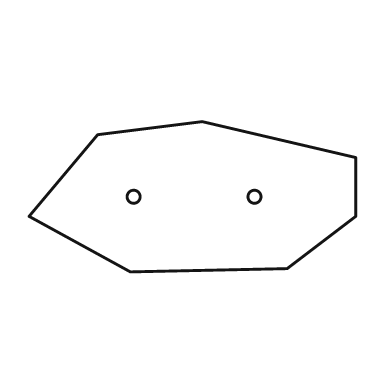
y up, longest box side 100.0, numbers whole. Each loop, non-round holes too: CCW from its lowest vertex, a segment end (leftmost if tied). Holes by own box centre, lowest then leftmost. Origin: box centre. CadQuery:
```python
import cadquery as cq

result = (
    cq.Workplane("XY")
    .moveTo(-19.0, -23.0)
    .lineTo(29.0, -22.0)
    .lineTo(50.0, -6.0)
    .lineTo(50.0, 12.0)
    .lineTo(3.0, 23.0)
    .lineTo(-29.0, 19.0)
    .lineTo(-50.0, -6.0)
    .close()
    .moveTo(-18.0, 0.0)
    .circle(2.0)
    .moveTo(19.0, 0.0)
    .circle(2.0)
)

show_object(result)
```